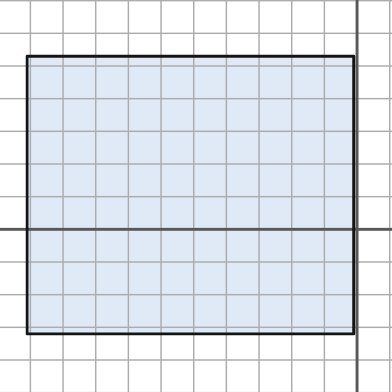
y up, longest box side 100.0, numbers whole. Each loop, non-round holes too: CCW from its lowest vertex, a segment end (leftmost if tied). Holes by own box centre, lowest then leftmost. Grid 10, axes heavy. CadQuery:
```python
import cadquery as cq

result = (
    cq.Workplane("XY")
    .moveTo(-101.0, -32.0)
    .lineTo(-1.0, -32.0)
    .lineTo(-1.0, 53.0)
    .lineTo(-101.0, 53.0)
    .close()
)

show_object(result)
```